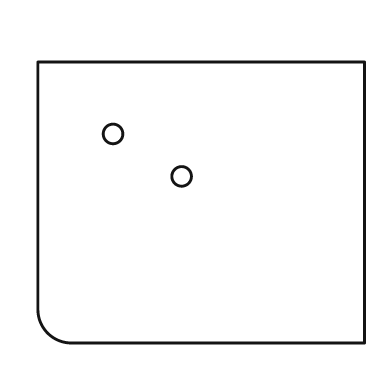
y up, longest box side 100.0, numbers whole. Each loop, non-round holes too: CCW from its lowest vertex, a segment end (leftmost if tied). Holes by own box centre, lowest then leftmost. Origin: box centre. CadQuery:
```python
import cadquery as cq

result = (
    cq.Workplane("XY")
    .moveTo(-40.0, -43.0)
    .lineTo(50.0, -43.0)
    .lineTo(50.0, 43.0)
    .lineTo(-50.0, 43.0)
    .lineTo(-50.0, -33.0)
    .threePointArc((-47.0, -40.0), (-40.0, -43.0))
    .close()
    .moveTo(-6.0, 8.0)
    .circle(3.0)
    .moveTo(-27.0, 21.0)
    .circle(3.0)
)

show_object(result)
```